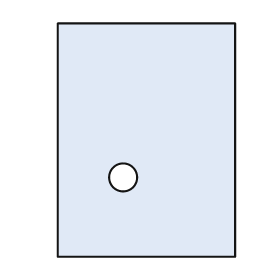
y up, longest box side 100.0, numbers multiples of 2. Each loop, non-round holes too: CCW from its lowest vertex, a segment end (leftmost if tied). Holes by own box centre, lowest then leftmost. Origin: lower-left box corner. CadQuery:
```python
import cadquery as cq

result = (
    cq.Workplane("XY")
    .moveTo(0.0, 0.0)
    .lineTo(76.0, 0.0)
    .lineTo(76.0, 100.0)
    .lineTo(0.0, 100.0)
    .close()
    .moveTo(28.0, 34.0)
    .circle(6.0)
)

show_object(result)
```